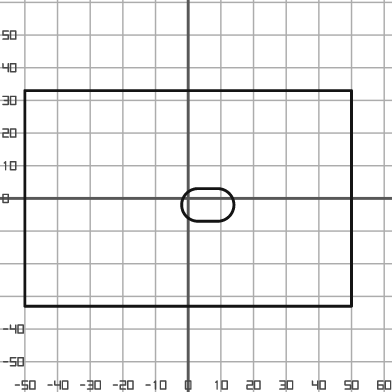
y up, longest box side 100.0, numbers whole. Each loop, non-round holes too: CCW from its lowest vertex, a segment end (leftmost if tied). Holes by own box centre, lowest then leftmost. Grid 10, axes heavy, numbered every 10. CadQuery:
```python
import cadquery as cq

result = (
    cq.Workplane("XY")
    .moveTo(-50.0, -33.0)
    .lineTo(50.0, -33.0)
    .lineTo(50.0, 33.0)
    .lineTo(-50.0, 33.0)
    .close()
    .moveTo(3.0, -7.0)
    .lineTo(9.0, -7.0)
    .threePointArc((14.0, -2.0), (9.0, 3.0))
    .lineTo(3.0, 3.0)
    .threePointArc((-2.0, -2.0), (3.0, -7.0))
    .close()
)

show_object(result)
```